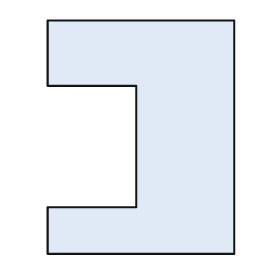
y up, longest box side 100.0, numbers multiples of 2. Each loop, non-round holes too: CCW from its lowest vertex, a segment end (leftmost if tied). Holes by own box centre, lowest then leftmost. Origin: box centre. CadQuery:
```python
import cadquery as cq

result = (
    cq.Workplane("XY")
    .moveTo(-40.0, -50.0)
    .lineTo(40.0, -50.0)
    .lineTo(40.0, 50.0)
    .lineTo(-40.0, 50.0)
    .lineTo(-40.0, 22.0)
    .lineTo(-2.0, 22.0)
    .lineTo(-2.0, -30.0)
    .lineTo(-40.0, -30.0)
    .close()
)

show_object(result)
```